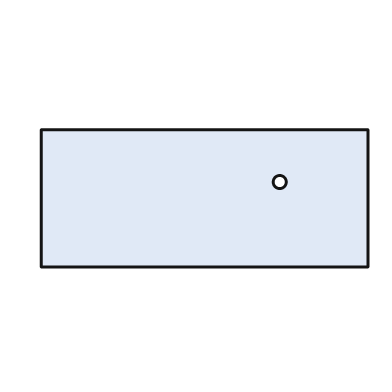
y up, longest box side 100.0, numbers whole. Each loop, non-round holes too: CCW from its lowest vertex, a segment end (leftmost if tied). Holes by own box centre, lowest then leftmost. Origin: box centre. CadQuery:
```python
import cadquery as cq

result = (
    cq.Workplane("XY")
    .moveTo(-50.0, -21.0)
    .lineTo(50.0, -21.0)
    .lineTo(50.0, 21.0)
    .lineTo(-50.0, 21.0)
    .close()
    .moveTo(23.0, 5.0)
    .circle(2.0)
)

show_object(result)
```